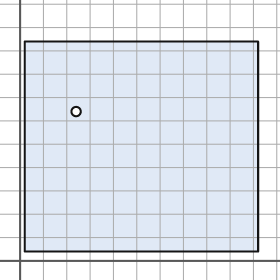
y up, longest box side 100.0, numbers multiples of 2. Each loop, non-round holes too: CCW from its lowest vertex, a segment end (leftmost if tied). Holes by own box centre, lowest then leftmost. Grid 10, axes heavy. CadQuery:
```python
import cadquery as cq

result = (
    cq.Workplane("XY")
    .moveTo(2.0, 4.0)
    .lineTo(102.0, 4.0)
    .lineTo(102.0, 94.0)
    .lineTo(2.0, 94.0)
    .close()
    .moveTo(24.0, 64.0)
    .circle(2.0)
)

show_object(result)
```